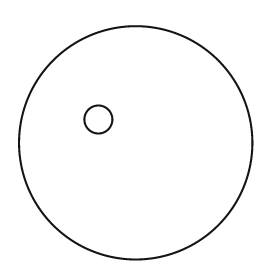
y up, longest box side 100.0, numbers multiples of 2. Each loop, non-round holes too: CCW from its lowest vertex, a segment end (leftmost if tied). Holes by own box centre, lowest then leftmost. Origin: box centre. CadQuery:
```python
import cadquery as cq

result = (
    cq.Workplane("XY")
    .moveTo(0.0, 0.0)
    .circle(50.0)
    .moveTo(-16.0, 10.0)
    .circle(6.0)
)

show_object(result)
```